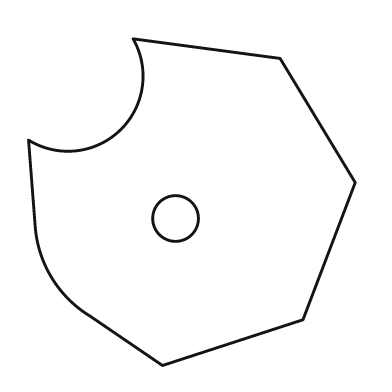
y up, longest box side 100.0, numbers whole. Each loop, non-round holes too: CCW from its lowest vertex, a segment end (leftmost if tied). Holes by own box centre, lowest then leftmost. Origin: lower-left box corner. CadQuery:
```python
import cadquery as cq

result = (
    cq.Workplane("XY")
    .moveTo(41.0, 0.0)
    .lineTo(84.0, 14.0)
    .lineTo(100.0, 56.0)
    .lineTo(77.0, 94.0)
    .lineTo(32.0, 100.0)
    .threePointArc((28.0, 72.0), (0.0, 69.0))
    .lineTo(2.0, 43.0)
    .threePointArc((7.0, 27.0), (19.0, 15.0))
    .close()
    .moveTo(45.0, 45.0)
    .circle(7.0)
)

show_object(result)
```